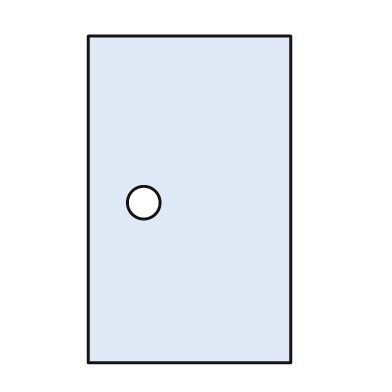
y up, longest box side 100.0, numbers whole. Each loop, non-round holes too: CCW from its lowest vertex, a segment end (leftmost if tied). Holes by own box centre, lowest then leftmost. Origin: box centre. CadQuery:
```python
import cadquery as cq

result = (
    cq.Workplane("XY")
    .moveTo(-31.0, -50.0)
    .lineTo(31.0, -50.0)
    .lineTo(31.0, 50.0)
    .lineTo(-31.0, 50.0)
    .close()
    .moveTo(-14.0, -1.0)
    .circle(5.0)
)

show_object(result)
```